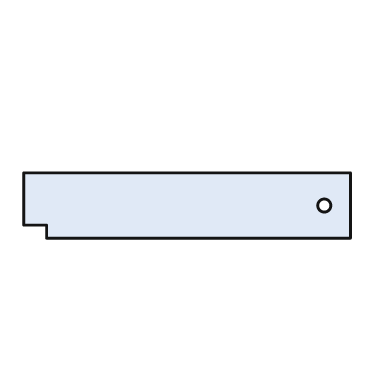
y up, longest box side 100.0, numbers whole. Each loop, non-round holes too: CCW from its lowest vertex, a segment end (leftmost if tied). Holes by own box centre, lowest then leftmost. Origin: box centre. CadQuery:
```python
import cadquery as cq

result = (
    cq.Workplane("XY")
    .moveTo(-43.0, -10.0)
    .lineTo(50.0, -10.0)
    .lineTo(50.0, 10.0)
    .lineTo(-50.0, 10.0)
    .lineTo(-50.0, -6.0)
    .lineTo(-43.0, -6.0)
    .close()
    .moveTo(42.0, 0.0)
    .circle(2.0)
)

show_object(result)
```